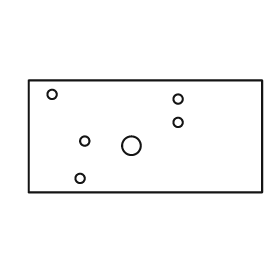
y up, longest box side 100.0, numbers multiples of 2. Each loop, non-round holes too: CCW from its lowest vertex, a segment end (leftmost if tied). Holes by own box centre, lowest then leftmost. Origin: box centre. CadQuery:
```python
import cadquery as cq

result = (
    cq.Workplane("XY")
    .moveTo(-50.0, -24.0)
    .lineTo(50.0, -24.0)
    .lineTo(50.0, 24.0)
    .lineTo(-50.0, 24.0)
    .close()
    .moveTo(-28.0, -18.0)
    .circle(2.0)
    .moveTo(-6.0, -4.0)
    .circle(4.0)
    .moveTo(-26.0, -2.0)
    .circle(2.0)
    .moveTo(14.0, 6.0)
    .circle(2.0)
    .moveTo(14.0, 16.0)
    .circle(2.0)
    .moveTo(-40.0, 18.0)
    .circle(2.0)
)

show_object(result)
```